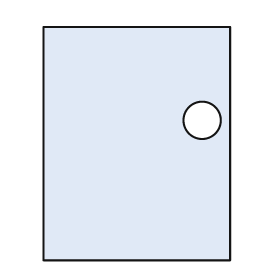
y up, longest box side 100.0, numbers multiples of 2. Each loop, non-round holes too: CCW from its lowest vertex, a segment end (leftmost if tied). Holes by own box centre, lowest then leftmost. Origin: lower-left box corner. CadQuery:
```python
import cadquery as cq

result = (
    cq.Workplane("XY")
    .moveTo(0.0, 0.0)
    .lineTo(80.0, 0.0)
    .lineTo(80.0, 100.0)
    .lineTo(0.0, 100.0)
    .close()
    .moveTo(68.0, 60.0)
    .circle(8.0)
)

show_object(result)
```